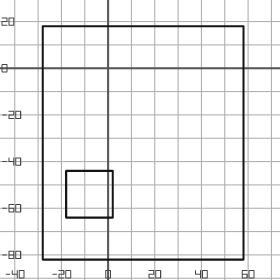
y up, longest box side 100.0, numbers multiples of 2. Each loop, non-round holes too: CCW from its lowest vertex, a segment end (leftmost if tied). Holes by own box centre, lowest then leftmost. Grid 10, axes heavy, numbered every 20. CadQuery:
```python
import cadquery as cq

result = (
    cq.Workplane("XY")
    .moveTo(-28.0, -82.0)
    .lineTo(58.0, -82.0)
    .lineTo(58.0, 18.0)
    .lineTo(-28.0, 18.0)
    .close()
    .moveTo(-18.0, -64.0)
    .lineTo(2.0, -64.0)
    .lineTo(2.0, -44.0)
    .lineTo(-18.0, -44.0)
    .close()
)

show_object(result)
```